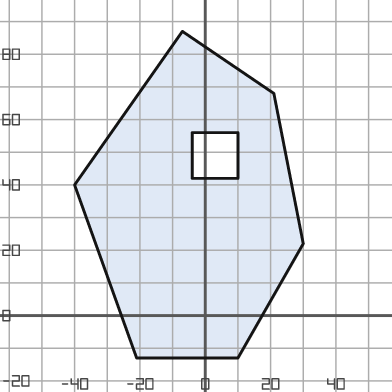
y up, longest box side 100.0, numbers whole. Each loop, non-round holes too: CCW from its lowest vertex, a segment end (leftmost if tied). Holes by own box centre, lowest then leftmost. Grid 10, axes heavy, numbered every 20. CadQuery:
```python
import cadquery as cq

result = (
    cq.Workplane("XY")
    .moveTo(-21.0, -13.0)
    .lineTo(10.0, -13.0)
    .lineTo(30.0, 22.0)
    .lineTo(21.0, 68.0)
    .lineTo(-7.0, 87.0)
    .lineTo(-40.0, 40.0)
    .close()
    .moveTo(-4.0, 42.0)
    .lineTo(10.0, 42.0)
    .lineTo(10.0, 56.0)
    .lineTo(-4.0, 56.0)
    .close()
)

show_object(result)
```